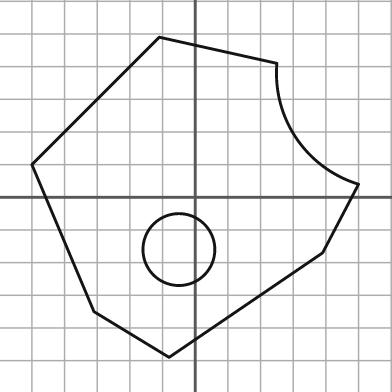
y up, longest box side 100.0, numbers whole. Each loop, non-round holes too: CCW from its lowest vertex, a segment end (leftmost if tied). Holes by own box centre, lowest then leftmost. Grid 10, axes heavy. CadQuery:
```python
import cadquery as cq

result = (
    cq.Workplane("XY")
    .moveTo(-8.0, -49.0)
    .lineTo(39.0, -17.0)
    .lineTo(50.0, 4.0)
    .threePointArc((31.0, 18.0), (25.0, 41.0))
    .lineTo(-11.0, 49.0)
    .lineTo(-50.0, 10.0)
    .lineTo(-31.0, -35.0)
    .close()
    .moveTo(-5.0, -16.0)
    .circle(11.0)
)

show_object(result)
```